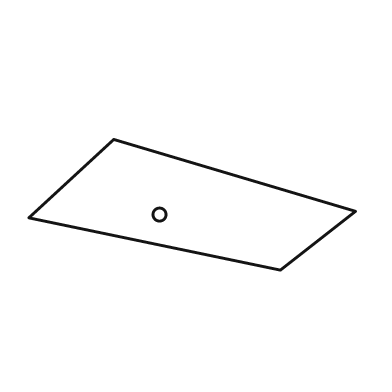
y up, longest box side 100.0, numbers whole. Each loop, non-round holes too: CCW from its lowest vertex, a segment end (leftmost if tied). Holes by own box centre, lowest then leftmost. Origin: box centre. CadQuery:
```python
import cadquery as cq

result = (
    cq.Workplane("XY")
    .moveTo(27.0, -20.0)
    .lineTo(50.0, -2.0)
    .lineTo(-24.0, 20.0)
    .lineTo(-50.0, -4.0)
    .close()
    .moveTo(-10.0, -3.0)
    .circle(2.0)
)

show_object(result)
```